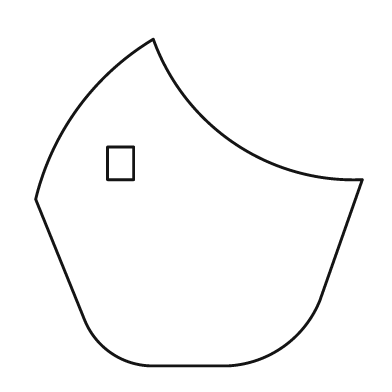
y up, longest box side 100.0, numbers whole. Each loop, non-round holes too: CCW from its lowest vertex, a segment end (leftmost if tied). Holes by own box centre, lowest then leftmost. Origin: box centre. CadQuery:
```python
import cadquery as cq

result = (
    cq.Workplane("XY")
    .moveTo(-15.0, -50.0)
    .lineTo(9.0, -50.0)
    .threePointArc((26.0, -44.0), (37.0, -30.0))
    .lineTo(50.0, 7.0)
    .threePointArc((11.0, 18.0), (-14.0, 50.0))
    .threePointArc((-37.0, 29.0), (-50.0, 1.0))
    .lineTo(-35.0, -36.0)
    .threePointArc((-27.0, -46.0), (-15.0, -50.0))
    .close()
    .moveTo(-28.0, 7.0)
    .lineTo(-20.0, 7.0)
    .lineTo(-20.0, 17.0)
    .lineTo(-28.0, 17.0)
    .close()
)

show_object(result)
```